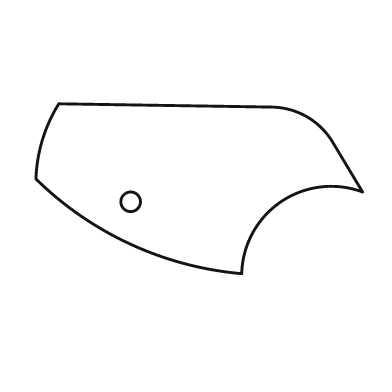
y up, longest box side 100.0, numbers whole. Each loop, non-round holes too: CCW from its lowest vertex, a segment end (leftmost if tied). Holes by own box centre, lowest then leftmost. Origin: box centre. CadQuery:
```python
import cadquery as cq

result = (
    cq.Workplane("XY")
    .moveTo(13.0, -26.0)
    .threePointArc((25.0, -4.0), (50.0, -1.0))
    .lineTo(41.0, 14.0)
    .threePointArc((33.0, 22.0), (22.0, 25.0))
    .lineTo(-43.0, 26.0)
    .threePointArc((-48.0, 15.0), (-50.0, 3.0))
    .threePointArc((-21.0, -17.0), (13.0, -26.0))
    .close()
    .moveTo(-21.0, -4.0)
    .circle(3.0)
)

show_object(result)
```